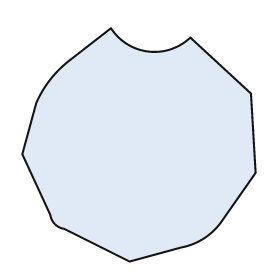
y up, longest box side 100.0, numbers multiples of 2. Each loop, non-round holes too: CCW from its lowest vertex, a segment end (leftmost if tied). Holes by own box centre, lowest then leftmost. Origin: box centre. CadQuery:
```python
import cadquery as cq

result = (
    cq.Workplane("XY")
    .moveTo(-4.0, -50.0)
    .lineTo(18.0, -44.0)
    .threePointArc((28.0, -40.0), (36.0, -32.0))
    .lineTo(50.0, -12.0)
    .lineTo(48.0, 22.0)
    .lineTo(22.0, 46.0)
    .threePointArc((4.0, 40.0), (-12.0, 50.0))
    .lineTo(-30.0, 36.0)
    .threePointArc((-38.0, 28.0), (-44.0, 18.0))
    .lineTo(-50.0, -4.0)
    .lineTo(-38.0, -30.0)
    .threePointArc((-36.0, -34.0), (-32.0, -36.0))
    .close()
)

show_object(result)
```